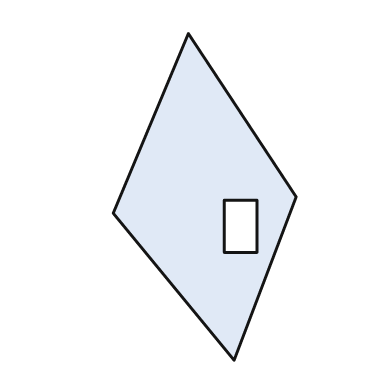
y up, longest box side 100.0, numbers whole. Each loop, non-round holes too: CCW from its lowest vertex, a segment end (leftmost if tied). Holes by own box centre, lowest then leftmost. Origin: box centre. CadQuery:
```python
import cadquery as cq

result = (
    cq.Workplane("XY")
    .moveTo(9.0, -50.0)
    .lineTo(28.0, 0.0)
    .lineTo(-5.0, 50.0)
    .lineTo(-28.0, -5.0)
    .close()
    .moveTo(6.0, -17.0)
    .lineTo(16.0, -17.0)
    .lineTo(16.0, -1.0)
    .lineTo(6.0, -1.0)
    .close()
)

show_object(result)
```